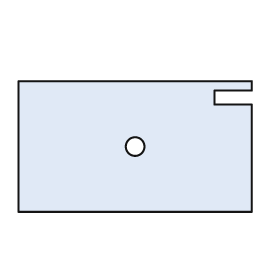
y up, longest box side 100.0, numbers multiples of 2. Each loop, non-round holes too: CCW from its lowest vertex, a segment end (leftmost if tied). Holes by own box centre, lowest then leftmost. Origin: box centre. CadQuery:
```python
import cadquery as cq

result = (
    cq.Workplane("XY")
    .moveTo(-50.0, -28.0)
    .lineTo(50.0, -28.0)
    .lineTo(50.0, 18.0)
    .lineTo(34.0, 18.0)
    .lineTo(34.0, 24.0)
    .lineTo(50.0, 24.0)
    .lineTo(50.0, 28.0)
    .lineTo(-50.0, 28.0)
    .close()
    .moveTo(0.0, 0.0)
    .circle(4.0)
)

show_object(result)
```